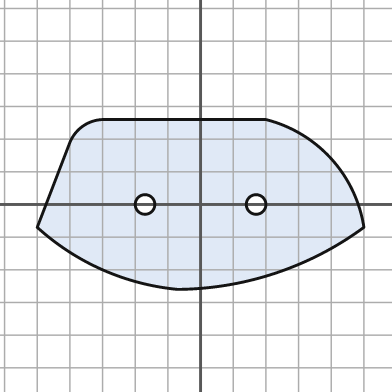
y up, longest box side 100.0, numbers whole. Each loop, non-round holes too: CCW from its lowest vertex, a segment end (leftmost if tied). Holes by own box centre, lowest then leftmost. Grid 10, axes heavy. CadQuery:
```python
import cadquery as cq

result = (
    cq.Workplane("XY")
    .moveTo(-7.0, -26.0)
    .threePointArc((23.0, -21.0), (50.0, -7.0))
    .threePointArc((40.0, 14.0), (20.0, 26.0))
    .lineTo(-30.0, 26.0)
    .threePointArc((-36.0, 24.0), (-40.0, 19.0))
    .lineTo(-50.0, -7.0)
    .threePointArc((-30.0, -20.0), (-7.0, -26.0))
    .close()
    .moveTo(-17.0, 0.0)
    .circle(3.0)
    .moveTo(17.0, 0.0)
    .circle(3.0)
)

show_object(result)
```